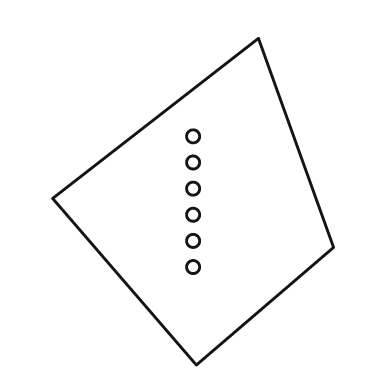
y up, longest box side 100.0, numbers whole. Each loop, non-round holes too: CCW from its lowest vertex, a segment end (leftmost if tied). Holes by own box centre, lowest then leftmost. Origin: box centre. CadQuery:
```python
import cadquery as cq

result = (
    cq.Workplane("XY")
    .moveTo(1.0, -50.0)
    .lineTo(43.0, -14.0)
    .lineTo(20.0, 50.0)
    .lineTo(-43.0, 1.0)
    .close()
    .moveTo(0.0, -20.0)
    .circle(2.0)
    .moveTo(0.0, -12.0)
    .circle(2.0)
    .moveTo(0.0, -4.0)
    .circle(2.0)
    .moveTo(0.0, 4.0)
    .circle(2.0)
    .moveTo(0.0, 12.0)
    .circle(2.0)
    .moveTo(0.0, 20.0)
    .circle(2.0)
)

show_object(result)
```